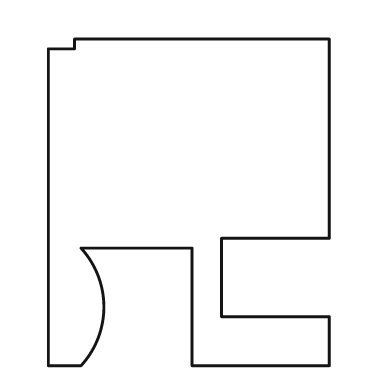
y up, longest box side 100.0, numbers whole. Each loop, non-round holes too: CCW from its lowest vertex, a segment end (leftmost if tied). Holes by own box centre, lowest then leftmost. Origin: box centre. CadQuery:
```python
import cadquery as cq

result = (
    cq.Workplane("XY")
    .moveTo(-43.0, -50.0)
    .lineTo(-33.0, -50.0)
    .threePointArc((-26.0, -32.0), (-33.0, -14.0))
    .lineTo(1.0, -14.0)
    .lineTo(1.0, -50.0)
    .lineTo(43.0, -50.0)
    .lineTo(43.0, -35.0)
    .lineTo(10.0, -35.0)
    .lineTo(10.0, -11.0)
    .lineTo(43.0, -11.0)
    .lineTo(43.0, 50.0)
    .lineTo(-35.0, 50.0)
    .lineTo(-35.0, 47.0)
    .lineTo(-43.0, 47.0)
    .close()
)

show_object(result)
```